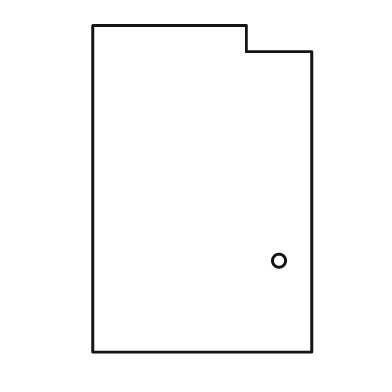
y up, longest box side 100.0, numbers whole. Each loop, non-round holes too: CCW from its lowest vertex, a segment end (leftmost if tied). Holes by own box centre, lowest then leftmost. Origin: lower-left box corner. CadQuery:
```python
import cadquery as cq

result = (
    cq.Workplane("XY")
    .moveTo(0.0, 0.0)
    .lineTo(67.0, 0.0)
    .lineTo(67.0, 92.0)
    .lineTo(47.0, 92.0)
    .lineTo(47.0, 100.0)
    .lineTo(0.0, 100.0)
    .close()
    .moveTo(57.0, 28.0)
    .circle(2.0)
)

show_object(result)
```